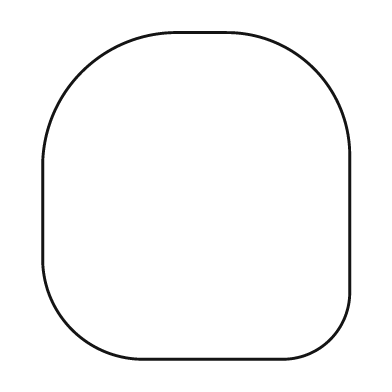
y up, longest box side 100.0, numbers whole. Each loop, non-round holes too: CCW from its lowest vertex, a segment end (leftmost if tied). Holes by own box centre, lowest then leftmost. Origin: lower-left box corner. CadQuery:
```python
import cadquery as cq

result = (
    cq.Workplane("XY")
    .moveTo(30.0, 0.0)
    .lineTo(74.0, 0.0)
    .threePointArc((88.0, 6.0), (94.0, 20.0))
    .lineTo(94.0, 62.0)
    .threePointArc((83.0, 89.0), (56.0, 100.0))
    .lineTo(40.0, 100.0)
    .threePointArc((12.0, 88.0), (0.0, 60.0))
    .lineTo(0.0, 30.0)
    .threePointArc((9.0, 9.0), (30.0, 0.0))
    .close()
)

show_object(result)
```